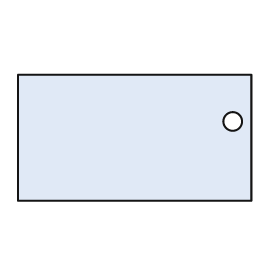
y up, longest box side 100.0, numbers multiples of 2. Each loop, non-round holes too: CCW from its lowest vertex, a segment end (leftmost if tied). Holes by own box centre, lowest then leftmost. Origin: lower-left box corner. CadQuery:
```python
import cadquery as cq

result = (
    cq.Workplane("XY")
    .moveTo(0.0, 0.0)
    .lineTo(100.0, 0.0)
    .lineTo(100.0, 54.0)
    .lineTo(0.0, 54.0)
    .close()
    .moveTo(92.0, 34.0)
    .circle(4.0)
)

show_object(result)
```